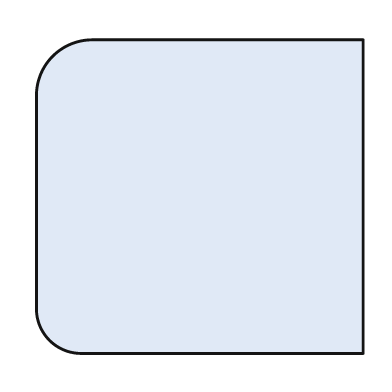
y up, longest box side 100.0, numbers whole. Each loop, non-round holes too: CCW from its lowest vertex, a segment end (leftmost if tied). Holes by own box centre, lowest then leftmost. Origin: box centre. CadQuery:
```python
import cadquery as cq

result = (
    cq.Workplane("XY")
    .moveTo(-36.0, -48.0)
    .lineTo(50.0, -48.0)
    .lineTo(50.0, 48.0)
    .lineTo(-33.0, 48.0)
    .threePointArc((-45.0, 43.0), (-50.0, 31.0))
    .lineTo(-50.0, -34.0)
    .threePointArc((-46.0, -44.0), (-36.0, -48.0))
    .close()
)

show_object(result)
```